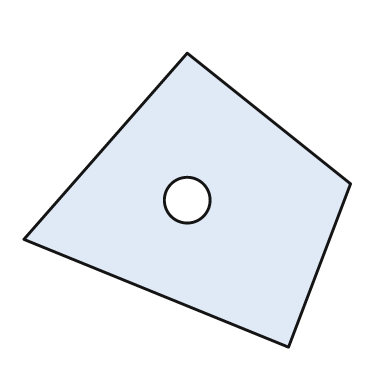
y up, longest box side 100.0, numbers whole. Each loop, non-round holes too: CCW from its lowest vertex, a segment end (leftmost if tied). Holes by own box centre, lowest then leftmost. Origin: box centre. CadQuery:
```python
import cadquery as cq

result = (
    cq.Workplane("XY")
    .moveTo(31.0, -45.0)
    .lineTo(50.0, 5.0)
    .lineTo(0.0, 45.0)
    .lineTo(-50.0, -12.0)
    .close()
    .moveTo(0.0, 0.0)
    .circle(7.0)
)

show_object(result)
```